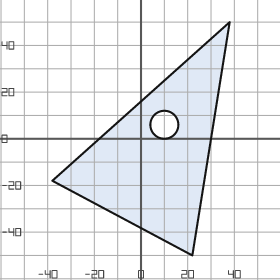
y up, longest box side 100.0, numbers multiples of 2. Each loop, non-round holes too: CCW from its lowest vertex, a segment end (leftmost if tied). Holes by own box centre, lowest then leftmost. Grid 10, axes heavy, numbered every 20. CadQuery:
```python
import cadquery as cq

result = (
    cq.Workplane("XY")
    .moveTo(22.0, -50.0)
    .lineTo(38.0, 50.0)
    .lineTo(-38.0, -18.0)
    .close()
    .moveTo(10.0, 6.0)
    .circle(6.0)
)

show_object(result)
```